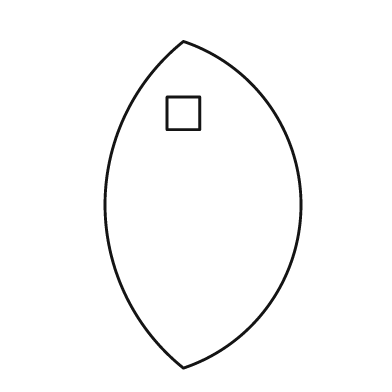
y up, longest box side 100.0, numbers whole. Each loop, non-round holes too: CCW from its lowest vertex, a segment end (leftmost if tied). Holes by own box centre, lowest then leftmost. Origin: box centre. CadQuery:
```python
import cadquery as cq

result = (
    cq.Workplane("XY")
    .moveTo(-6.0, -50.0)
    .threePointArc((30.0, 0.0), (-6.0, 50.0))
    .threePointArc((-30.0, 0.0), (-6.0, -50.0))
    .close()
    .moveTo(-11.0, 23.0)
    .lineTo(-1.0, 23.0)
    .lineTo(-1.0, 33.0)
    .lineTo(-11.0, 33.0)
    .close()
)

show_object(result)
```